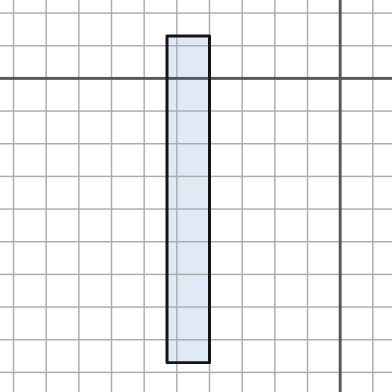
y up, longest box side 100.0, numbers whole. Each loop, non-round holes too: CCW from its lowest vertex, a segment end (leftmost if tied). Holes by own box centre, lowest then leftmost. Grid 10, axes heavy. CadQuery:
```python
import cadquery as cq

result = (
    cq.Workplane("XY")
    .moveTo(-53.0, -87.0)
    .lineTo(-40.0, -87.0)
    .lineTo(-40.0, 13.0)
    .lineTo(-53.0, 13.0)
    .close()
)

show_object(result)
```